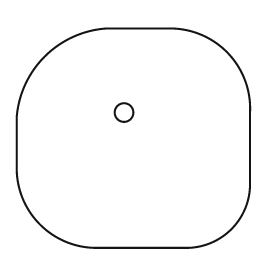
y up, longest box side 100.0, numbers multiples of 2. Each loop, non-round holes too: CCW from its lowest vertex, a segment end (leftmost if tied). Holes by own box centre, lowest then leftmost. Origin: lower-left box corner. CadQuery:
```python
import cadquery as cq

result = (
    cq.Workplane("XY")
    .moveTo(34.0, 0.0)
    .lineTo(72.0, 0.0)
    .threePointArc((92.0, 8.0), (100.0, 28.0))
    .lineTo(100.0, 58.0)
    .threePointArc((90.0, 84.0), (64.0, 94.0))
    .lineTo(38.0, 94.0)
    .threePointArc((12.0, 82.0), (0.0, 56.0))
    .lineTo(0.0, 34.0)
    .threePointArc((10.0, 10.0), (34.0, 0.0))
    .close()
    .moveTo(46.0, 58.0)
    .circle(4.0)
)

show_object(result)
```